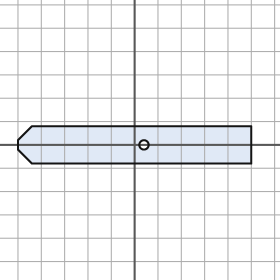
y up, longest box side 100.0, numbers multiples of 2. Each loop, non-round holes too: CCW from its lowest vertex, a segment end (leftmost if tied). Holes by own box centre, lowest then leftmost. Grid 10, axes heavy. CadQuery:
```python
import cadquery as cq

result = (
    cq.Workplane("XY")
    .moveTo(-44.0, -8.0)
    .lineTo(50.0, -8.0)
    .lineTo(50.0, 8.0)
    .lineTo(-44.0, 8.0)
    .lineTo(-50.0, 2.0)
    .lineTo(-50.0, -2.0)
    .close()
    .moveTo(4.0, 0.0)
    .circle(2.0)
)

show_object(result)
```